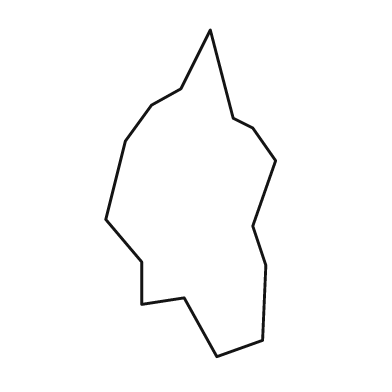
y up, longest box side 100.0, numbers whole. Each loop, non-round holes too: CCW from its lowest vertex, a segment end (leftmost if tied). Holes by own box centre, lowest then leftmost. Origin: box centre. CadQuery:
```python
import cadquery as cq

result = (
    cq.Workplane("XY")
    .moveTo(8.0, -50.0)
    .lineTo(22.0, -45.0)
    .lineTo(23.0, -22.0)
    .lineTo(19.0, -10.0)
    .lineTo(26.0, 10.0)
    .lineTo(19.0, 20.0)
    .lineTo(13.0, 23.0)
    .lineTo(6.0, 50.0)
    .lineTo(-3.0, 32.0)
    .lineTo(-12.0, 27.0)
    .lineTo(-20.0, 16.0)
    .lineTo(-26.0, -8.0)
    .lineTo(-15.0, -21.0)
    .lineTo(-15.0, -34.0)
    .lineTo(-2.0, -32.0)
    .close()
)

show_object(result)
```